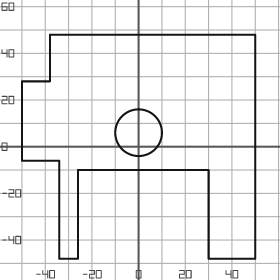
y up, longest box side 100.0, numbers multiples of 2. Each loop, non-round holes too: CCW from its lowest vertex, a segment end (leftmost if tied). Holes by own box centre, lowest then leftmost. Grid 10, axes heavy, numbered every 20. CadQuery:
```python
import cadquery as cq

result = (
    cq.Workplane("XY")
    .moveTo(-34.0, -48.0)
    .lineTo(-26.0, -48.0)
    .lineTo(-26.0, -10.0)
    .lineTo(30.0, -10.0)
    .lineTo(30.0, -48.0)
    .lineTo(50.0, -48.0)
    .lineTo(50.0, 48.0)
    .lineTo(-38.0, 48.0)
    .lineTo(-38.0, 28.0)
    .lineTo(-50.0, 28.0)
    .lineTo(-50.0, -6.0)
    .lineTo(-34.0, -6.0)
    .close()
    .moveTo(0.0, 6.0)
    .circle(10.0)
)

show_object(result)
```